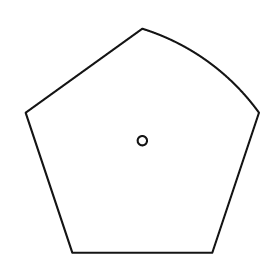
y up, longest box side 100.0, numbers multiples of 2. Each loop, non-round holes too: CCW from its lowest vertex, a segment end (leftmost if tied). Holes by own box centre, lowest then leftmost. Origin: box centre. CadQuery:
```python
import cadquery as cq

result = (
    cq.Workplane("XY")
    .moveTo(-30.0, -48.0)
    .lineTo(30.0, -48.0)
    .lineTo(50.0, 12.0)
    .threePointArc((28.0, 34.0), (0.0, 48.0))
    .lineTo(-50.0, 12.0)
    .close()
    .moveTo(0.0, 0.0)
    .circle(2.0)
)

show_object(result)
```